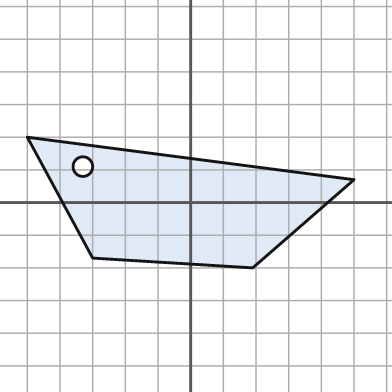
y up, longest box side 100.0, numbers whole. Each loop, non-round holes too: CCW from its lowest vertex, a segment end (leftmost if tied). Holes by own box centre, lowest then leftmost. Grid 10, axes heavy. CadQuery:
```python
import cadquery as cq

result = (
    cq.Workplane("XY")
    .moveTo(19.0, -20.0)
    .lineTo(50.0, 7.0)
    .lineTo(-50.0, 20.0)
    .lineTo(-30.0, -17.0)
    .close()
    .moveTo(-33.0, 11.0)
    .circle(3.0)
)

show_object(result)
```